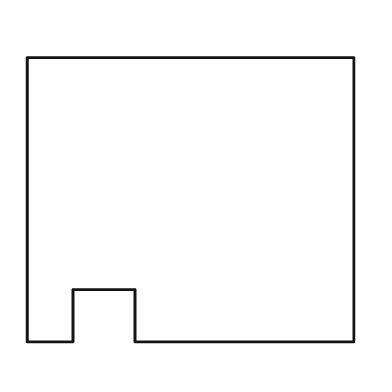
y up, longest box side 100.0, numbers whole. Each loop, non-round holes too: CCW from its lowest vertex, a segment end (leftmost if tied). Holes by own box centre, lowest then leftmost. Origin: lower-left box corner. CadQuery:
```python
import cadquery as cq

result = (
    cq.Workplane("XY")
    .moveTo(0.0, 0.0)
    .lineTo(14.0, 0.0)
    .lineTo(14.0, 16.0)
    .lineTo(33.0, 16.0)
    .lineTo(33.0, 0.0)
    .lineTo(100.0, 0.0)
    .lineTo(100.0, 87.0)
    .lineTo(0.0, 87.0)
    .close()
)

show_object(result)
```